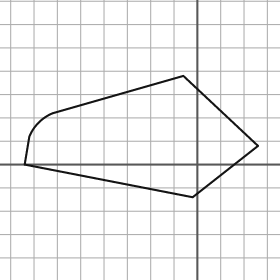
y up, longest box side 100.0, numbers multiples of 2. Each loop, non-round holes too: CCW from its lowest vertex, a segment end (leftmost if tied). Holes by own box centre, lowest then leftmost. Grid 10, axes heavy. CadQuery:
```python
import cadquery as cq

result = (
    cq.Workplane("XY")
    .moveTo(-2.0, -14.0)
    .lineTo(26.0, 8.0)
    .lineTo(-6.0, 38.0)
    .lineTo(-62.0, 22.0)
    .threePointArc((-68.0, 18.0), (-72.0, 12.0))
    .lineTo(-74.0, 0.0)
    .close()
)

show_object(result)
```